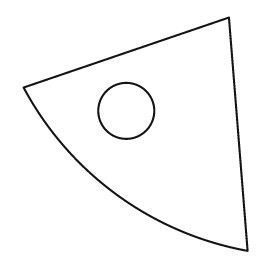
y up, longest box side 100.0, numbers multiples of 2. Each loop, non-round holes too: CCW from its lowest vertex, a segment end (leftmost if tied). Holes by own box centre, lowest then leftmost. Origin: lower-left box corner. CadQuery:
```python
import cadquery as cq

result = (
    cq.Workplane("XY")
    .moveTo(96.0, 0.0)
    .lineTo(88.0, 100.0)
    .lineTo(0.0, 70.0)
    .threePointArc((40.0, 24.0), (96.0, 0.0))
    .close()
    .moveTo(44.0, 60.0)
    .circle(12.0)
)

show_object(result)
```